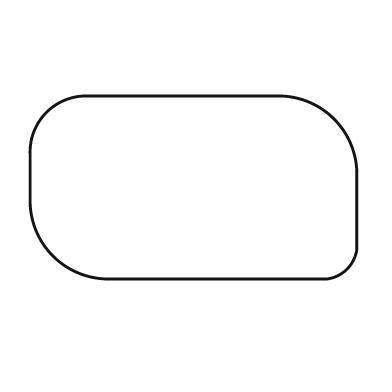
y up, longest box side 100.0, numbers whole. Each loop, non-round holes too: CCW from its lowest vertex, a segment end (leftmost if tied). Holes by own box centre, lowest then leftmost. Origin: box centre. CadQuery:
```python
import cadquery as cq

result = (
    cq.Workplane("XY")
    .moveTo(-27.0, -28.0)
    .lineTo(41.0, -28.0)
    .threePointArc((47.0, -25.0), (50.0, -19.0))
    .lineTo(50.0, 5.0)
    .threePointArc((43.0, 21.0), (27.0, 28.0))
    .lineTo(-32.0, 28.0)
    .threePointArc((-45.0, 23.0), (-50.0, 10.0))
    .lineTo(-50.0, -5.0)
    .threePointArc((-43.0, -21.0), (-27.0, -28.0))
    .close()
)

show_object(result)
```